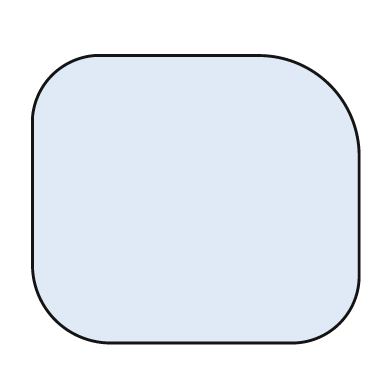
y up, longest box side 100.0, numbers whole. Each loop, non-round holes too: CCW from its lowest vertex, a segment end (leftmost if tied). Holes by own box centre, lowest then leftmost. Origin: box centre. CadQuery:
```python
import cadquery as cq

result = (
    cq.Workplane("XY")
    .moveTo(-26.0, -44.0)
    .lineTo(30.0, -44.0)
    .threePointArc((44.0, -38.0), (50.0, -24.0))
    .lineTo(50.0, 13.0)
    .threePointArc((41.0, 35.0), (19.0, 44.0))
    .lineTo(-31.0, 44.0)
    .threePointArc((-44.0, 38.0), (-50.0, 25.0))
    .lineTo(-50.0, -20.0)
    .threePointArc((-43.0, -37.0), (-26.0, -44.0))
    .close()
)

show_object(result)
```